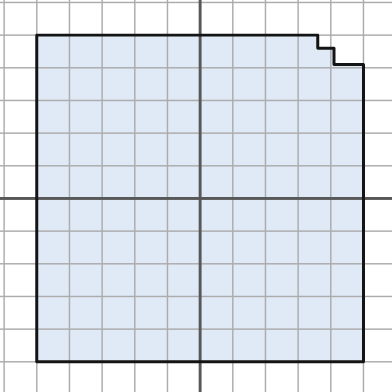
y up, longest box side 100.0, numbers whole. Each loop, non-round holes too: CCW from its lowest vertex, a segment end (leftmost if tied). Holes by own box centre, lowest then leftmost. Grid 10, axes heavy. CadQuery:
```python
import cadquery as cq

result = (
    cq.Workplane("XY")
    .moveTo(-50.0, -50.0)
    .lineTo(50.0, -50.0)
    .lineTo(50.0, 41.0)
    .lineTo(41.0, 41.0)
    .lineTo(41.0, 46.0)
    .lineTo(36.0, 46.0)
    .lineTo(36.0, 50.0)
    .lineTo(-50.0, 50.0)
    .close()
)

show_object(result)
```